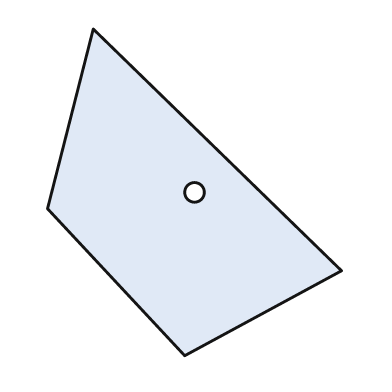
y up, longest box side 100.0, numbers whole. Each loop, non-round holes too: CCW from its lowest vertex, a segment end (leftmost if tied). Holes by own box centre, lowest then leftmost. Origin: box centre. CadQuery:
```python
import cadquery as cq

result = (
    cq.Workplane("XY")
    .moveTo(-3.0, -50.0)
    .lineTo(45.0, -24.0)
    .lineTo(-31.0, 50.0)
    .lineTo(-45.0, -5.0)
    .close()
    .moveTo(0.0, 0.0)
    .circle(3.0)
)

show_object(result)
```